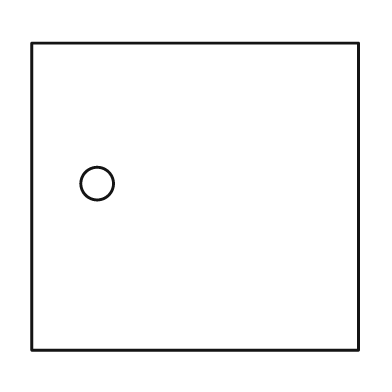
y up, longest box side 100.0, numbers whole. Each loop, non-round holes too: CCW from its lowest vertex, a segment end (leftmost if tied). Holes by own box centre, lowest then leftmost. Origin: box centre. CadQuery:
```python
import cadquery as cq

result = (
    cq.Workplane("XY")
    .moveTo(-50.0, -47.0)
    .lineTo(50.0, -47.0)
    .lineTo(50.0, 47.0)
    .lineTo(-50.0, 47.0)
    .close()
    .moveTo(-30.0, 4.0)
    .circle(5.0)
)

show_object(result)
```